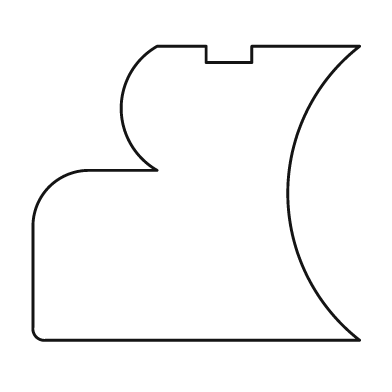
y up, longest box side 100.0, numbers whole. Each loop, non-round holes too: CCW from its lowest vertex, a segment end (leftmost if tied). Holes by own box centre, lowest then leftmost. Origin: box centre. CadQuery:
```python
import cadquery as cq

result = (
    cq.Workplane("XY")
    .moveTo(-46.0, -45.0)
    .lineTo(50.0, -45.0)
    .threePointArc((28.0, 0.0), (50.0, 45.0))
    .lineTo(17.0, 45.0)
    .lineTo(17.0, 40.0)
    .lineTo(3.0, 40.0)
    .lineTo(3.0, 45.0)
    .lineTo(-12.0, 45.0)
    .threePointArc((-23.0, 26.0), (-12.0, 7.0))
    .lineTo(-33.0, 7.0)
    .threePointArc((-45.0, 2.0), (-50.0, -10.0))
    .lineTo(-50.0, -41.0)
    .threePointArc((-49.0, -44.0), (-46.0, -45.0))
    .close()
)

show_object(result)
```